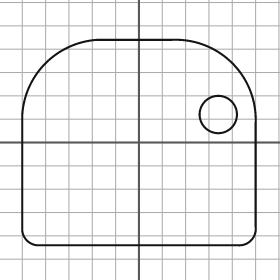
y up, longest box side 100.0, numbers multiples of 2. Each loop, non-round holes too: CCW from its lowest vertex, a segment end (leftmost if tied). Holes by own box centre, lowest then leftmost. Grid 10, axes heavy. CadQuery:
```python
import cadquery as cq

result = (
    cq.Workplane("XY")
    .moveTo(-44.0, -44.0)
    .lineTo(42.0, -44.0)
    .threePointArc((48.0, -42.0), (50.0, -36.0))
    .lineTo(50.0, 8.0)
    .threePointArc((40.0, 34.0), (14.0, 44.0))
    .lineTo(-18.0, 44.0)
    .threePointArc((-40.0, 34.0), (-50.0, 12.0))
    .lineTo(-50.0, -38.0)
    .threePointArc((-48.0, -42.0), (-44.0, -44.0))
    .close()
    .moveTo(34.0, 12.0)
    .circle(8.0)
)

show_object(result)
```